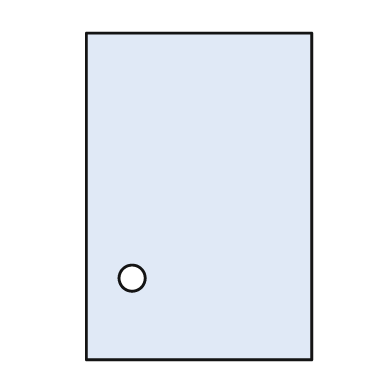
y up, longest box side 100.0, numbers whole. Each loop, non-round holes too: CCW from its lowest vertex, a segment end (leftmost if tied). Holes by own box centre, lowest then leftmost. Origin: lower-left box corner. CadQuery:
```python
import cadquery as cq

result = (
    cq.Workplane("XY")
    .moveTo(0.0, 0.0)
    .lineTo(69.0, 0.0)
    .lineTo(69.0, 100.0)
    .lineTo(0.0, 100.0)
    .close()
    .moveTo(14.0, 25.0)
    .circle(4.0)
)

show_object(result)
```